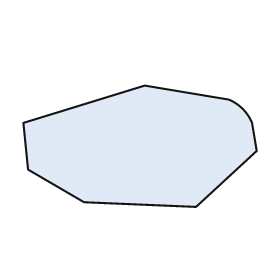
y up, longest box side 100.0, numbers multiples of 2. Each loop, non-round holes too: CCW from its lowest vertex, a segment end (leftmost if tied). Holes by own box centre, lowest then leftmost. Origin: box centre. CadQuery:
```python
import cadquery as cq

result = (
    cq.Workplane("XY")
    .moveTo(24.0, -26.0)
    .lineTo(50.0, -2.0)
    .lineTo(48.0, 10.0)
    .threePointArc((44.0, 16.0), (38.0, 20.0))
    .lineTo(2.0, 26.0)
    .lineTo(-50.0, 10.0)
    .lineTo(-48.0, -10.0)
    .lineTo(-24.0, -24.0)
    .close()
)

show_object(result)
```